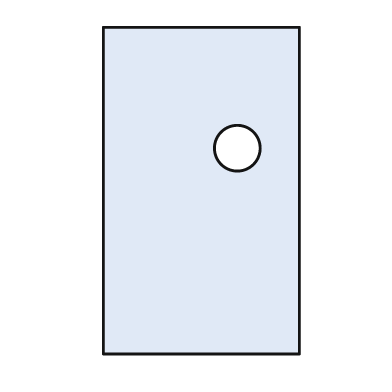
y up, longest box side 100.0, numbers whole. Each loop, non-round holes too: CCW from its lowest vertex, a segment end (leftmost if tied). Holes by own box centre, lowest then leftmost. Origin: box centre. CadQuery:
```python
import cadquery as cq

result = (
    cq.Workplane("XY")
    .moveTo(-30.0, -50.0)
    .lineTo(30.0, -50.0)
    .lineTo(30.0, 50.0)
    .lineTo(-30.0, 50.0)
    .close()
    .moveTo(11.0, 13.0)
    .circle(7.0)
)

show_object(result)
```